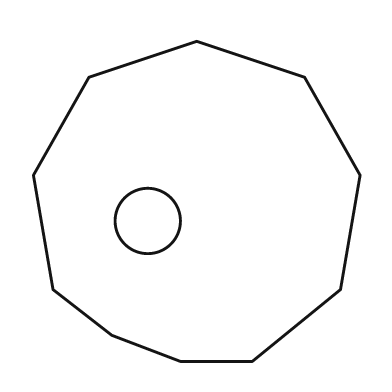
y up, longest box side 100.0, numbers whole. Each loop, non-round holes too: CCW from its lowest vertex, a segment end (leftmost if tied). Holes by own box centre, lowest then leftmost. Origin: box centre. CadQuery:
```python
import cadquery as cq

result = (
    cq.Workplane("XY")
    .moveTo(-5.0, -49.0)
    .lineTo(17.0, -49.0)
    .lineTo(44.0, -27.0)
    .lineTo(50.0, 8.0)
    .lineTo(33.0, 38.0)
    .lineTo(0.0, 49.0)
    .lineTo(-33.0, 38.0)
    .lineTo(-50.0, 8.0)
    .lineTo(-44.0, -27.0)
    .lineTo(-26.0, -41.0)
    .close()
    .moveTo(-15.0, -6.0)
    .circle(10.0)
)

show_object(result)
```